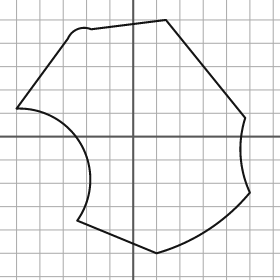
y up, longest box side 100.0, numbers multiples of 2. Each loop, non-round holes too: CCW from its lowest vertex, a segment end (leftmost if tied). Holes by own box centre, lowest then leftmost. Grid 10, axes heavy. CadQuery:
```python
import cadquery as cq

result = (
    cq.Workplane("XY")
    .moveTo(10.0, -50.0)
    .threePointArc((32.0, -40.0), (50.0, -24.0))
    .threePointArc((46.0, -8.0), (48.0, 8.0))
    .lineTo(14.0, 50.0)
    .lineTo(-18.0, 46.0)
    .threePointArc((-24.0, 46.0), (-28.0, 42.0))
    .lineTo(-50.0, 12.0)
    .threePointArc((-22.0, -4.0), (-24.0, -36.0))
    .close()
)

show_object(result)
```